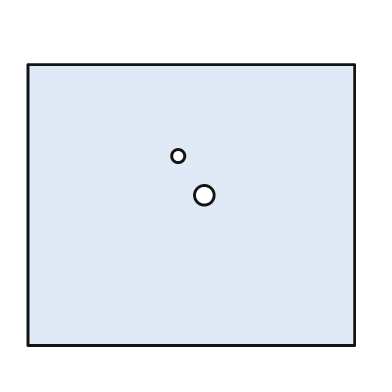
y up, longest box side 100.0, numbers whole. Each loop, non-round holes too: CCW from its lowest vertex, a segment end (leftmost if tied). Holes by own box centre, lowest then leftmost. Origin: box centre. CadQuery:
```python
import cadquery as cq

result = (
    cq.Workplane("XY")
    .moveTo(-50.0, -43.0)
    .lineTo(50.0, -43.0)
    .lineTo(50.0, 43.0)
    .lineTo(-50.0, 43.0)
    .close()
    .moveTo(4.0, 3.0)
    .circle(3.0)
    .moveTo(-4.0, 15.0)
    .circle(2.0)
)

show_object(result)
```